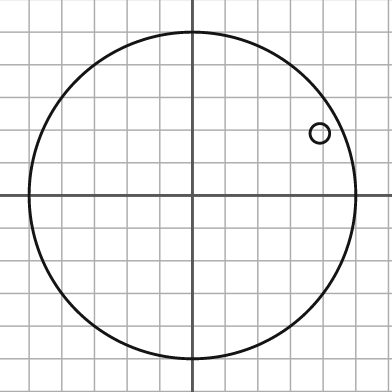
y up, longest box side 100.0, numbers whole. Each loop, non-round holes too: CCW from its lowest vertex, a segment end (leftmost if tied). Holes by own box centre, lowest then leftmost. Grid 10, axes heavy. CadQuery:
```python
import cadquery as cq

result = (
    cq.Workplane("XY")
    .moveTo(0.0, 0.0)
    .circle(50.0)
    .moveTo(39.0, 19.0)
    .circle(3.0)
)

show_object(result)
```